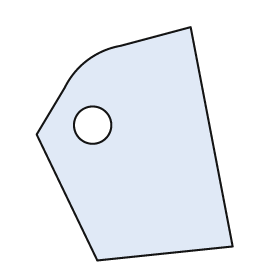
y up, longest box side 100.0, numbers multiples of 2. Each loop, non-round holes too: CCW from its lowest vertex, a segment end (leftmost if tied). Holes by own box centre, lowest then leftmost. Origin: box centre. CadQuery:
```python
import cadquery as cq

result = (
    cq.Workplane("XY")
    .moveTo(-16.0, -50.0)
    .lineTo(42.0, -44.0)
    .lineTo(24.0, 50.0)
    .lineTo(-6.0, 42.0)
    .threePointArc((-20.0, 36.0), (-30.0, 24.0))
    .lineTo(-42.0, 4.0)
    .close()
    .moveTo(-18.0, 8.0)
    .circle(8.0)
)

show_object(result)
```